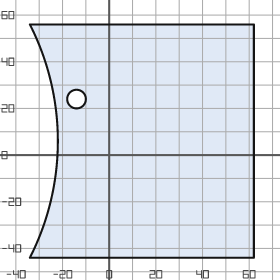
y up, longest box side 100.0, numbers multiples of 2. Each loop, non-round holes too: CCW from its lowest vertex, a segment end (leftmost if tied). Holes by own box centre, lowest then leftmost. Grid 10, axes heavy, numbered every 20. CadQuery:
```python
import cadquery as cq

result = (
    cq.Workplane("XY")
    .moveTo(-34.0, -44.0)
    .lineTo(62.0, -44.0)
    .lineTo(62.0, 56.0)
    .lineTo(-34.0, 56.0)
    .threePointArc((-22.0, 6.0), (-34.0, -44.0))
    .close()
    .moveTo(-14.0, 24.0)
    .circle(4.0)
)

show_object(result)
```